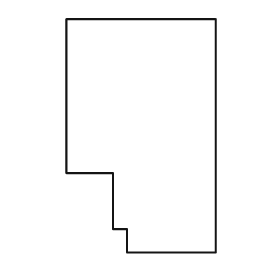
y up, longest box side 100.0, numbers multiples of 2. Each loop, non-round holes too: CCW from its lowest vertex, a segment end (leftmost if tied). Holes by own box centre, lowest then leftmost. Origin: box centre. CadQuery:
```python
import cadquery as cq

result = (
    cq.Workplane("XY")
    .moveTo(-6.0, -50.0)
    .lineTo(32.0, -50.0)
    .lineTo(32.0, 50.0)
    .lineTo(-32.0, 50.0)
    .lineTo(-32.0, -16.0)
    .lineTo(-12.0, -16.0)
    .lineTo(-12.0, -40.0)
    .lineTo(-6.0, -40.0)
    .close()
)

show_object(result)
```